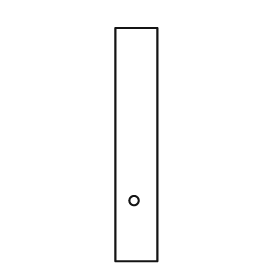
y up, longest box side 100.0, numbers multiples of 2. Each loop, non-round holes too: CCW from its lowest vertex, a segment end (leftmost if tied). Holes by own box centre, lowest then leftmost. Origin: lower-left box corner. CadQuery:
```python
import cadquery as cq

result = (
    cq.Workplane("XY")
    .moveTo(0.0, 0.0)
    .lineTo(18.0, 0.0)
    .lineTo(18.0, 100.0)
    .lineTo(0.0, 100.0)
    .close()
    .moveTo(8.0, 26.0)
    .circle(2.0)
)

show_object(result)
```